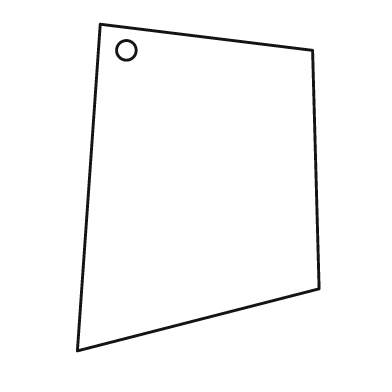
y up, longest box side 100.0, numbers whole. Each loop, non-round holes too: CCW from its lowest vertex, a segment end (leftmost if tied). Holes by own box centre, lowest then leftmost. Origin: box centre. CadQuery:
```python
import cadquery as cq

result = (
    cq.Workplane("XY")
    .moveTo(-37.0, -50.0)
    .lineTo(37.0, -31.0)
    .lineTo(35.0, 42.0)
    .lineTo(-30.0, 50.0)
    .close()
    .moveTo(-22.0, 42.0)
    .circle(3.0)
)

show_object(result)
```